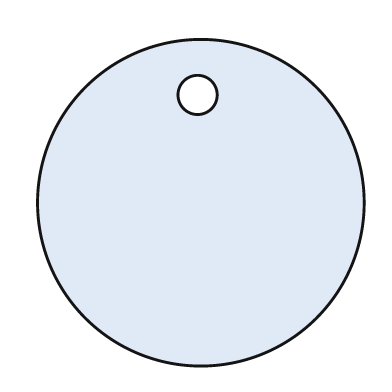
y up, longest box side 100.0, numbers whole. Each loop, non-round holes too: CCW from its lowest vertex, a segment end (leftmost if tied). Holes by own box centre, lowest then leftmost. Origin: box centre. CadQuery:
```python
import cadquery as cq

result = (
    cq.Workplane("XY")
    .moveTo(0.0, 0.0)
    .circle(50.0)
    .moveTo(-1.0, 33.0)
    .circle(6.0)
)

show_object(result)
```